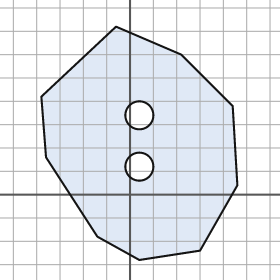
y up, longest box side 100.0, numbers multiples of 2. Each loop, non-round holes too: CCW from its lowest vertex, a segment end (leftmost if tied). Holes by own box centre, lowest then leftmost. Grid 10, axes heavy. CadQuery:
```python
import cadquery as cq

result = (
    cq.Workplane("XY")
    .moveTo(4.0, -28.0)
    .lineTo(30.0, -24.0)
    .lineTo(46.0, 4.0)
    .lineTo(44.0, 38.0)
    .lineTo(22.0, 60.0)
    .lineTo(-6.0, 72.0)
    .lineTo(-38.0, 42.0)
    .lineTo(-36.0, 16.0)
    .lineTo(-14.0, -18.0)
    .close()
    .moveTo(4.0, 12.0)
    .circle(6.0)
    .moveTo(4.0, 34.0)
    .circle(6.0)
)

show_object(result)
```